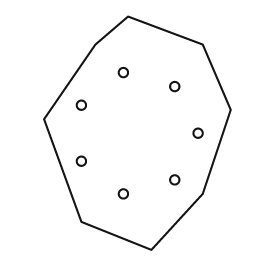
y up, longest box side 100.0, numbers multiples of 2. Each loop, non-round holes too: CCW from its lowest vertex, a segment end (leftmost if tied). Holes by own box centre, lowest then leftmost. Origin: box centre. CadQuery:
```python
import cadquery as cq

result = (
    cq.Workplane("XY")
    .moveTo(6.0, -50.0)
    .lineTo(28.0, -26.0)
    .lineTo(40.0, 10.0)
    .lineTo(28.0, 38.0)
    .lineTo(-4.0, 50.0)
    .lineTo(-18.0, 38.0)
    .lineTo(-40.0, 6.0)
    .lineTo(-24.0, -38.0)
    .close()
    .moveTo(-6.0, -26.0)
    .circle(2.0)
    .moveTo(16.0, -20.0)
    .circle(2.0)
    .moveTo(-24.0, -12.0)
    .circle(2.0)
    .moveTo(26.0, 0.0)
    .circle(2.0)
    .moveTo(-24.0, 12.0)
    .circle(2.0)
    .moveTo(16.0, 20.0)
    .circle(2.0)
    .moveTo(-6.0, 26.0)
    .circle(2.0)
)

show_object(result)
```